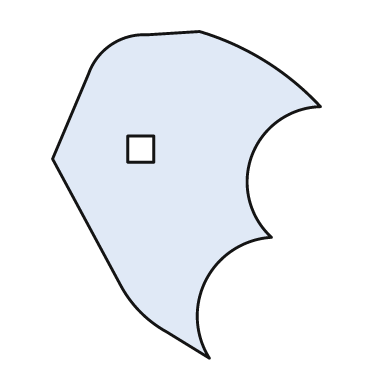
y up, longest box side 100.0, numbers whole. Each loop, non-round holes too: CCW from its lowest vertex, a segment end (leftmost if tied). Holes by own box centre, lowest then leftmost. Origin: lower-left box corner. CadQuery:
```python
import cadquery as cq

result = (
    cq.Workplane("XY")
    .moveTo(48.0, 0.0)
    .threePointArc((47.0, 24.0), (67.0, 37.0))
    .threePointArc((61.0, 62.0), (82.0, 77.0))
    .threePointArc((65.0, 91.0), (45.0, 100.0))
    .lineTo(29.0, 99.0)
    .threePointArc((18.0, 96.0), (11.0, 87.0))
    .lineTo(0.0, 61.0)
    .lineTo(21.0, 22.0)
    .threePointArc((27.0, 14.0), (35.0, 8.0))
    .close()
    .moveTo(23.0, 60.0)
    .lineTo(31.0, 60.0)
    .lineTo(31.0, 68.0)
    .lineTo(23.0, 68.0)
    .close()
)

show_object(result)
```